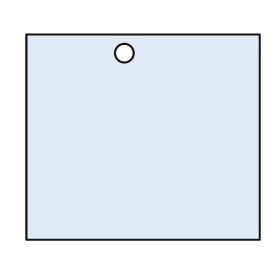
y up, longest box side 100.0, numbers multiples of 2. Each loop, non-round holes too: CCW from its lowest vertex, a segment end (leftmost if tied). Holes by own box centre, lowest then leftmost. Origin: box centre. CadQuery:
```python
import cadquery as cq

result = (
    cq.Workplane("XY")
    .moveTo(-50.0, -44.0)
    .lineTo(50.0, -44.0)
    .lineTo(50.0, 44.0)
    .lineTo(-50.0, 44.0)
    .close()
    .moveTo(-8.0, 36.0)
    .circle(4.0)
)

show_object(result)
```